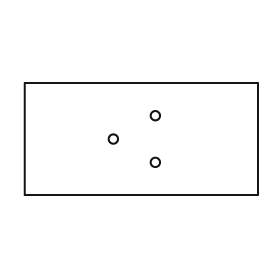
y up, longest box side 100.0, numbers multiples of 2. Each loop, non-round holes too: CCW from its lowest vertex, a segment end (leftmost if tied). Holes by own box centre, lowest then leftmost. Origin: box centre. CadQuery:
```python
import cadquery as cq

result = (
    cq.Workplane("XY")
    .moveTo(-50.0, -24.0)
    .lineTo(50.0, -24.0)
    .lineTo(50.0, 24.0)
    .lineTo(-50.0, 24.0)
    .close()
    .moveTo(6.0, -10.0)
    .circle(2.0)
    .moveTo(-12.0, 0.0)
    .circle(2.0)
    .moveTo(6.0, 10.0)
    .circle(2.0)
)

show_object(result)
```